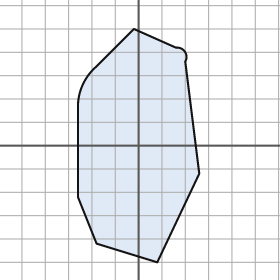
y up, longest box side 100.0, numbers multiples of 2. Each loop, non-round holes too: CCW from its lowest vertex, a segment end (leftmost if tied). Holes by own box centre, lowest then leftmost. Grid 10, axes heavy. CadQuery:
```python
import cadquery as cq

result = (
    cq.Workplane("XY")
    .moveTo(8.0, -50.0)
    .lineTo(26.0, -12.0)
    .lineTo(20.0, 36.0)
    .threePointArc((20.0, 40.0), (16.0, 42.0))
    .lineTo(-2.0, 50.0)
    .lineTo(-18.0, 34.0)
    .threePointArc((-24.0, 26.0), (-26.0, 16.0))
    .lineTo(-26.0, -22.0)
    .lineTo(-18.0, -42.0)
    .close()
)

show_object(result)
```